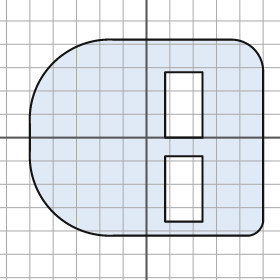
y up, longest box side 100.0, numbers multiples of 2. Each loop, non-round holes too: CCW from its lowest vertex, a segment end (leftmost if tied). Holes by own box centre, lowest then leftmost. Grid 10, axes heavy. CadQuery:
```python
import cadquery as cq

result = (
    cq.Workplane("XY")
    .moveTo(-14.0, -42.0)
    .lineTo(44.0, -42.0)
    .threePointArc((48.0, -40.0), (50.0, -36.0))
    .lineTo(50.0, 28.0)
    .threePointArc((46.0, 38.0), (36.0, 42.0))
    .lineTo(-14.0, 42.0)
    .threePointArc((-40.0, 32.0), (-50.0, 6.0))
    .lineTo(-50.0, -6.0)
    .threePointArc((-40.0, -32.0), (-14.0, -42.0))
    .close()
    .moveTo(8.0, -36.0)
    .lineTo(24.0, -36.0)
    .lineTo(24.0, -8.0)
    .lineTo(8.0, -8.0)
    .close()
    .moveTo(8.0, 0.0)
    .lineTo(24.0, 0.0)
    .lineTo(24.0, 28.0)
    .lineTo(8.0, 28.0)
    .close()
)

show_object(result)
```